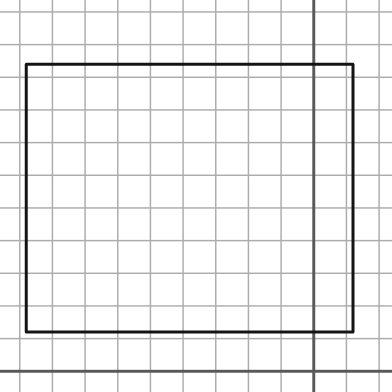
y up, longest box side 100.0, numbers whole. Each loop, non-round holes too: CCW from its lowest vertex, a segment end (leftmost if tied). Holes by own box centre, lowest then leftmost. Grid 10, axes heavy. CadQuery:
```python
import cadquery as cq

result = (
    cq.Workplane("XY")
    .moveTo(-88.0, 12.0)
    .lineTo(12.0, 12.0)
    .lineTo(12.0, 94.0)
    .lineTo(-88.0, 94.0)
    .close()
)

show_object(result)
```